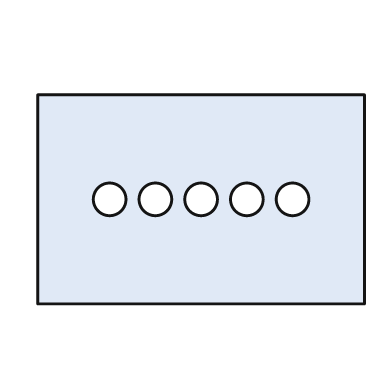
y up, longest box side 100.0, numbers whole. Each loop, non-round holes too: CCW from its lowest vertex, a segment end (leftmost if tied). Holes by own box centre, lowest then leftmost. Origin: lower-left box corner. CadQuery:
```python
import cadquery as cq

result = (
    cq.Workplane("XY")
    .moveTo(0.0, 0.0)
    .lineTo(100.0, 0.0)
    .lineTo(100.0, 64.0)
    .lineTo(0.0, 64.0)
    .close()
    .moveTo(22.0, 32.0)
    .circle(5.0)
    .moveTo(36.0, 32.0)
    .circle(5.0)
    .moveTo(50.0, 32.0)
    .circle(5.0)
    .moveTo(64.0, 32.0)
    .circle(5.0)
    .moveTo(78.0, 32.0)
    .circle(5.0)
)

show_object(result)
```